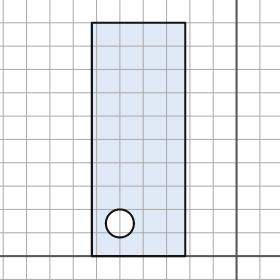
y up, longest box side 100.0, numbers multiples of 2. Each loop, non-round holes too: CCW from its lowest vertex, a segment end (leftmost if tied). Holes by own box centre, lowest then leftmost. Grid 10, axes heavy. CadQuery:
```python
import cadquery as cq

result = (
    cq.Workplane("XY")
    .moveTo(-62.0, 0.0)
    .lineTo(-22.0, 0.0)
    .lineTo(-22.0, 100.0)
    .lineTo(-62.0, 100.0)
    .close()
    .moveTo(-50.0, 14.0)
    .circle(6.0)
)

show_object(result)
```